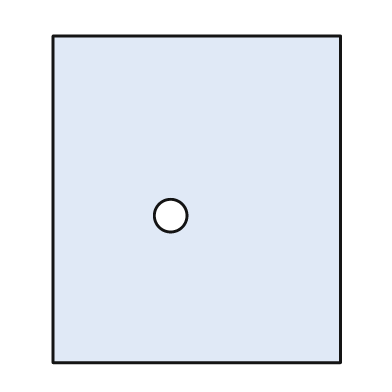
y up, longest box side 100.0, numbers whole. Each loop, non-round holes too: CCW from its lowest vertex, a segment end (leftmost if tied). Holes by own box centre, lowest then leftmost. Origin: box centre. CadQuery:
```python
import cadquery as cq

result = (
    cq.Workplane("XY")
    .moveTo(-44.0, -50.0)
    .lineTo(44.0, -50.0)
    .lineTo(44.0, 50.0)
    .lineTo(-44.0, 50.0)
    .close()
    .moveTo(-8.0, -5.0)
    .circle(5.0)
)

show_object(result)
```